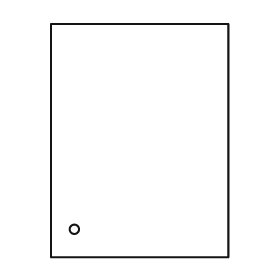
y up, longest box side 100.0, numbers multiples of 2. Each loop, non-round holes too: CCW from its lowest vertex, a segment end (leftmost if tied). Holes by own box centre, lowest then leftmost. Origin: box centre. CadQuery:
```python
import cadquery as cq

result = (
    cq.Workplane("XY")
    .moveTo(-38.0, -50.0)
    .lineTo(38.0, -50.0)
    .lineTo(38.0, 50.0)
    .lineTo(-38.0, 50.0)
    .close()
    .moveTo(-28.0, -38.0)
    .circle(2.0)
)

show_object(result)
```